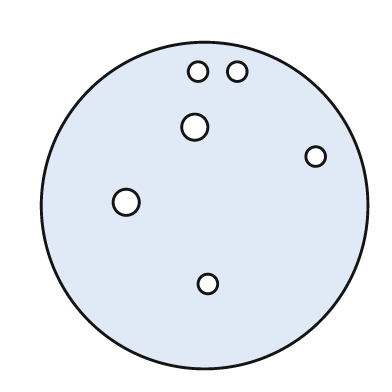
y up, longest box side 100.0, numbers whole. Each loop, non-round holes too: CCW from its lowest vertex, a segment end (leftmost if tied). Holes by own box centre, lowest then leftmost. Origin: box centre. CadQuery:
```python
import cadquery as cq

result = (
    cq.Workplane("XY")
    .moveTo(0.0, 0.0)
    .circle(50.0)
    .moveTo(1.0, -24.0)
    .circle(3.0)
    .moveTo(-24.0, 1.0)
    .circle(4.0)
    .moveTo(34.0, 15.0)
    .circle(3.0)
    .moveTo(-3.0, 24.0)
    .circle(4.0)
    .moveTo(-2.0, 41.0)
    .circle(3.0)
    .moveTo(10.0, 41.0)
    .circle(3.0)
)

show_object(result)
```